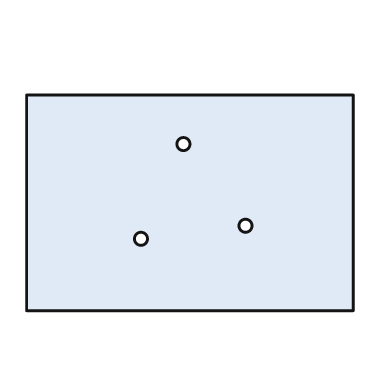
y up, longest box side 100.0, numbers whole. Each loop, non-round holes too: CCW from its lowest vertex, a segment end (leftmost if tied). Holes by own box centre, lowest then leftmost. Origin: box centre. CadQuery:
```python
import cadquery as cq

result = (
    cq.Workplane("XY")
    .moveTo(-50.0, -33.0)
    .lineTo(50.0, -33.0)
    .lineTo(50.0, 33.0)
    .lineTo(-50.0, 33.0)
    .close()
    .moveTo(-15.0, -11.0)
    .circle(2.0)
    .moveTo(17.0, -7.0)
    .circle(2.0)
    .moveTo(-2.0, 18.0)
    .circle(2.0)
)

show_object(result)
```